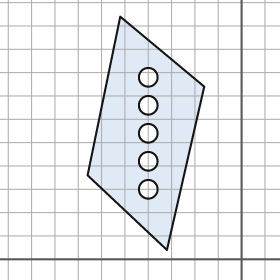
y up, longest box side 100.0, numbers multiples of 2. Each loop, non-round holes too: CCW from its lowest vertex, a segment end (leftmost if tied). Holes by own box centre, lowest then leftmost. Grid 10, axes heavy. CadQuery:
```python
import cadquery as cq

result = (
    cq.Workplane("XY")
    .moveTo(-32.0, 4.0)
    .lineTo(-16.0, 74.0)
    .lineTo(-52.0, 104.0)
    .lineTo(-66.0, 36.0)
    .close()
    .moveTo(-40.0, 30.0)
    .circle(4.0)
    .moveTo(-40.0, 42.0)
    .circle(4.0)
    .moveTo(-40.0, 54.0)
    .circle(4.0)
    .moveTo(-40.0, 66.0)
    .circle(4.0)
    .moveTo(-40.0, 78.0)
    .circle(4.0)
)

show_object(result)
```